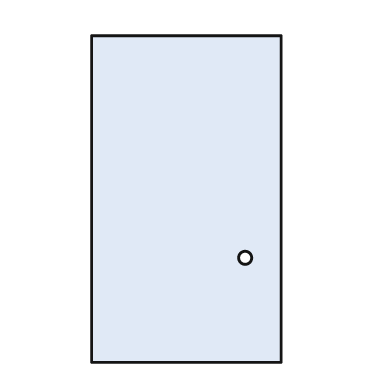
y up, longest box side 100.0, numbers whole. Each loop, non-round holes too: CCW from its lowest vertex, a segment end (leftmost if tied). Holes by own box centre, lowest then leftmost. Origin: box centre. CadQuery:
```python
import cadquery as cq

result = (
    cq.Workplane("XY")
    .moveTo(-29.0, -50.0)
    .lineTo(29.0, -50.0)
    .lineTo(29.0, 50.0)
    .lineTo(-29.0, 50.0)
    .close()
    .moveTo(18.0, -18.0)
    .circle(2.0)
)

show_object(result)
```